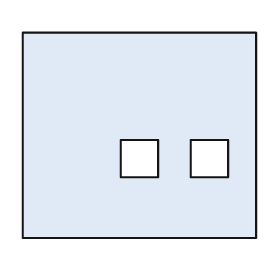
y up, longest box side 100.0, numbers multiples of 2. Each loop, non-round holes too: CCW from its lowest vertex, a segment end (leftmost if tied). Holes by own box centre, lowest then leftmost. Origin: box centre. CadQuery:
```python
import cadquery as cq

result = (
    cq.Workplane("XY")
    .moveTo(-50.0, -44.0)
    .lineTo(50.0, -44.0)
    .lineTo(50.0, 44.0)
    .lineTo(-50.0, 44.0)
    .close()
    .moveTo(-8.0, -18.0)
    .lineTo(8.0, -18.0)
    .lineTo(8.0, -2.0)
    .lineTo(-8.0, -2.0)
    .close()
    .moveTo(22.0, -18.0)
    .lineTo(38.0, -18.0)
    .lineTo(38.0, -2.0)
    .lineTo(22.0, -2.0)
    .close()
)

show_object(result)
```